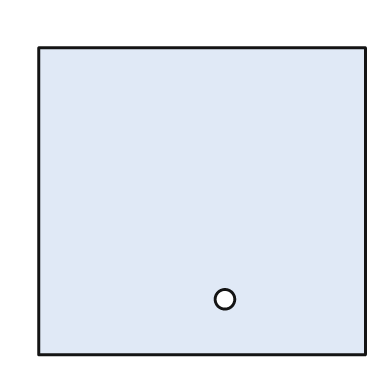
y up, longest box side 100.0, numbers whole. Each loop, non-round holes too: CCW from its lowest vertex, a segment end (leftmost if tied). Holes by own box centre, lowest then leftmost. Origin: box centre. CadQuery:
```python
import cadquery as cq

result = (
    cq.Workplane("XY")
    .moveTo(-50.0, -47.0)
    .lineTo(50.0, -47.0)
    .lineTo(50.0, 47.0)
    .lineTo(-50.0, 47.0)
    .close()
    .moveTo(7.0, -30.0)
    .circle(3.0)
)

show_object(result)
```